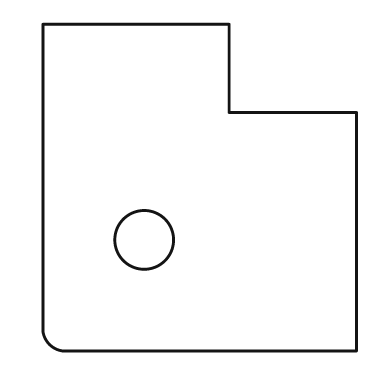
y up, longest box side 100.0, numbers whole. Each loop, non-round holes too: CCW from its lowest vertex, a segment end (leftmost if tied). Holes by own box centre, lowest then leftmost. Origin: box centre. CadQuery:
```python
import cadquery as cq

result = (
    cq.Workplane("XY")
    .moveTo(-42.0, -50.0)
    .lineTo(48.0, -50.0)
    .lineTo(48.0, 23.0)
    .lineTo(9.0, 23.0)
    .lineTo(9.0, 50.0)
    .lineTo(-48.0, 50.0)
    .lineTo(-48.0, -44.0)
    .threePointArc((-46.0, -48.0), (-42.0, -50.0))
    .close()
    .moveTo(-17.0, -16.0)
    .circle(9.0)
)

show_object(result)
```